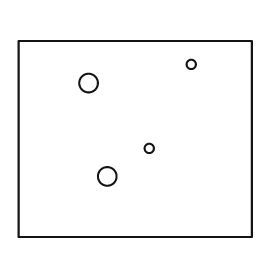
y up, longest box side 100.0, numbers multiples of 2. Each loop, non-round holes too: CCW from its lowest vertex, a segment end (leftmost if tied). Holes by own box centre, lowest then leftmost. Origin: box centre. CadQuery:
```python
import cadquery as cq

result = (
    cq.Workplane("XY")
    .moveTo(-50.0, -42.0)
    .lineTo(50.0, -42.0)
    .lineTo(50.0, 42.0)
    .lineTo(-50.0, 42.0)
    .close()
    .moveTo(-12.0, -16.0)
    .circle(4.0)
    .moveTo(6.0, -4.0)
    .circle(2.0)
    .moveTo(-20.0, 24.0)
    .circle(4.0)
    .moveTo(24.0, 32.0)
    .circle(2.0)
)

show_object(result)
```